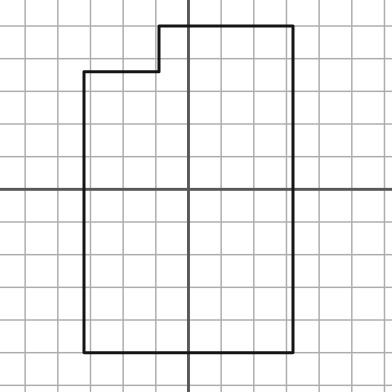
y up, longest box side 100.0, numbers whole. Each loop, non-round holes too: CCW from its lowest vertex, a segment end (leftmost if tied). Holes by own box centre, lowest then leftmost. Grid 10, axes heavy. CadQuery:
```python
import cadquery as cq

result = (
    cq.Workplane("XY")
    .moveTo(-32.0, -50.0)
    .lineTo(32.0, -50.0)
    .lineTo(32.0, 50.0)
    .lineTo(-9.0, 50.0)
    .lineTo(-9.0, 36.0)
    .lineTo(-32.0, 36.0)
    .close()
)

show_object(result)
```